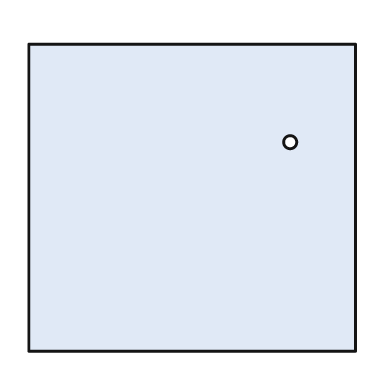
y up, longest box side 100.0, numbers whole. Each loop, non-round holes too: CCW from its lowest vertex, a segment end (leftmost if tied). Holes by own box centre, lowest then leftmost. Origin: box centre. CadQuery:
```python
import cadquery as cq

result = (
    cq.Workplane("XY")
    .moveTo(-50.0, -47.0)
    .lineTo(50.0, -47.0)
    .lineTo(50.0, 47.0)
    .lineTo(-50.0, 47.0)
    .close()
    .moveTo(30.0, 17.0)
    .circle(2.0)
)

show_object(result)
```